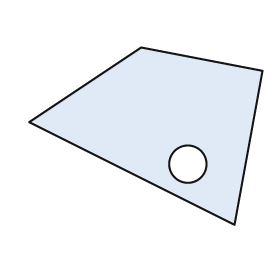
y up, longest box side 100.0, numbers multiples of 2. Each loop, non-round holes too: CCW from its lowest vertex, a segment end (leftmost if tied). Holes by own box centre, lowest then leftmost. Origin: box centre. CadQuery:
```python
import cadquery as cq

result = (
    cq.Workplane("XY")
    .moveTo(38.0, -38.0)
    .lineTo(50.0, 28.0)
    .lineTo(-2.0, 38.0)
    .lineTo(-50.0, 6.0)
    .close()
    .moveTo(18.0, -12.0)
    .circle(8.0)
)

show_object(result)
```